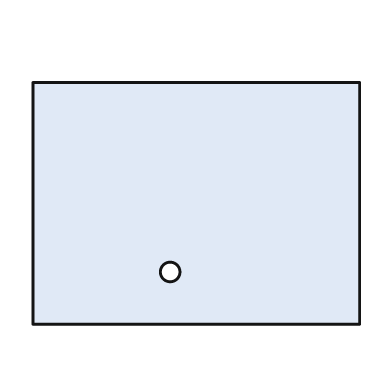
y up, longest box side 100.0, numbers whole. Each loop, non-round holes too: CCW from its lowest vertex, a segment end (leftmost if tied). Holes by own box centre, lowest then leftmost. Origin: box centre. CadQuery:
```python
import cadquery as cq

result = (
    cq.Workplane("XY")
    .moveTo(-50.0, -37.0)
    .lineTo(50.0, -37.0)
    .lineTo(50.0, 37.0)
    .lineTo(-50.0, 37.0)
    .close()
    .moveTo(-8.0, -21.0)
    .circle(3.0)
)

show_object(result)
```